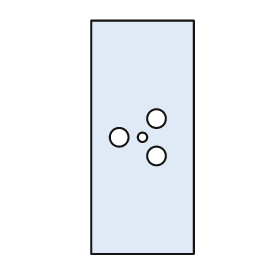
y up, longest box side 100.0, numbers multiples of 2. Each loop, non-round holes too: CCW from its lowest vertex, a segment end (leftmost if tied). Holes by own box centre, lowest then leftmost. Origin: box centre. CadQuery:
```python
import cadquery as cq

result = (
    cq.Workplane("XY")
    .moveTo(-22.0, -50.0)
    .lineTo(22.0, -50.0)
    .lineTo(22.0, 50.0)
    .lineTo(-22.0, 50.0)
    .close()
    .moveTo(6.0, -8.0)
    .circle(4.0)
    .moveTo(-10.0, 0.0)
    .circle(4.0)
    .moveTo(0.0, 0.0)
    .circle(2.0)
    .moveTo(6.0, 8.0)
    .circle(4.0)
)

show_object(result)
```